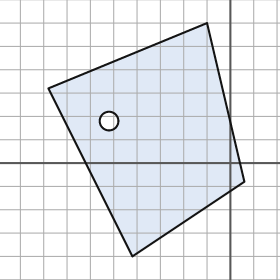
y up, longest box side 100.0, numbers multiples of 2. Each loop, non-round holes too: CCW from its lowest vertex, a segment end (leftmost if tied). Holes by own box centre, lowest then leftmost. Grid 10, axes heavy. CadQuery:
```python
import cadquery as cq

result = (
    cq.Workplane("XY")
    .moveTo(-42.0, -40.0)
    .lineTo(6.0, -8.0)
    .lineTo(-10.0, 60.0)
    .lineTo(-78.0, 32.0)
    .close()
    .moveTo(-52.0, 18.0)
    .circle(4.0)
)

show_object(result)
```